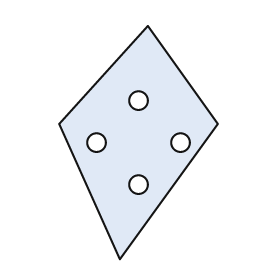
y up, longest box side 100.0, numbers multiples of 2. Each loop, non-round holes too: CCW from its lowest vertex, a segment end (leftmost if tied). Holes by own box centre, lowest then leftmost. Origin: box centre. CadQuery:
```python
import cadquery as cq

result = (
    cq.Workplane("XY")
    .moveTo(-8.0, -50.0)
    .lineTo(34.0, 8.0)
    .lineTo(4.0, 50.0)
    .lineTo(-34.0, 8.0)
    .close()
    .moveTo(0.0, -18.0)
    .circle(4.0)
    .moveTo(-18.0, 0.0)
    .circle(4.0)
    .moveTo(18.0, 0.0)
    .circle(4.0)
    .moveTo(0.0, 18.0)
    .circle(4.0)
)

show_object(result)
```